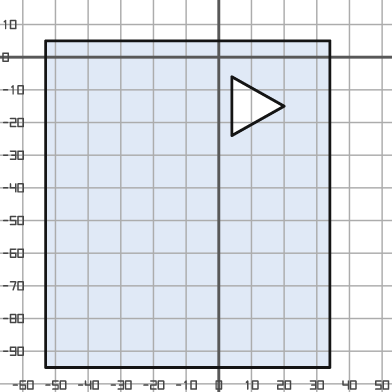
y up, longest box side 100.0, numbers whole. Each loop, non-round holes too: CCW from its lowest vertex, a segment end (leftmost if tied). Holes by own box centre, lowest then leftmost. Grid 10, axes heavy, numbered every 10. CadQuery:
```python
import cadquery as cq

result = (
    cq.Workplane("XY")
    .moveTo(-53.0, -95.0)
    .lineTo(34.0, -95.0)
    .lineTo(34.0, 5.0)
    .lineTo(-53.0, 5.0)
    .close()
    .moveTo(4.0, -24.0)
    .lineTo(20.0, -15.0)
    .lineTo(4.0, -6.0)
    .close()
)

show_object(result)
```